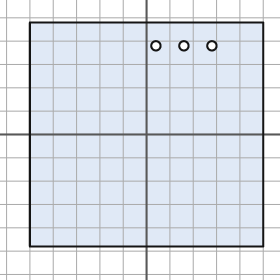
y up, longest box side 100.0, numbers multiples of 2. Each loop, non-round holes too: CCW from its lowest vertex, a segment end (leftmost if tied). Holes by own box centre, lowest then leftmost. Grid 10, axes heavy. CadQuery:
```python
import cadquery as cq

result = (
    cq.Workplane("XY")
    .moveTo(-50.0, -48.0)
    .lineTo(50.0, -48.0)
    .lineTo(50.0, 48.0)
    .lineTo(-50.0, 48.0)
    .close()
    .moveTo(4.0, 38.0)
    .circle(2.0)
    .moveTo(16.0, 38.0)
    .circle(2.0)
    .moveTo(28.0, 38.0)
    .circle(2.0)
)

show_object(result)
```